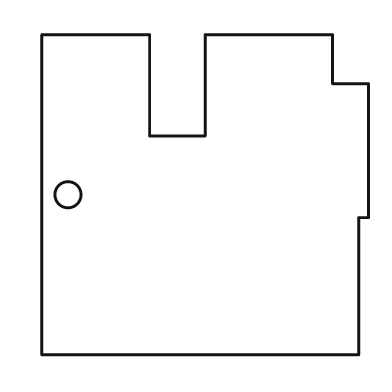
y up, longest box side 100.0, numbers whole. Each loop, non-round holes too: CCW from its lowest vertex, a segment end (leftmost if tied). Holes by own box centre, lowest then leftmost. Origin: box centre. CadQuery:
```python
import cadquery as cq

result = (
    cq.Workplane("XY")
    .moveTo(-50.0, -49.0)
    .lineTo(47.0, -49.0)
    .lineTo(47.0, -7.0)
    .lineTo(50.0, -7.0)
    .lineTo(50.0, 34.0)
    .lineTo(39.0, 34.0)
    .lineTo(39.0, 49.0)
    .lineTo(0.0, 49.0)
    .lineTo(0.0, 18.0)
    .lineTo(-17.0, 18.0)
    .lineTo(-17.0, 49.0)
    .lineTo(-50.0, 49.0)
    .close()
    .moveTo(-42.0, 0.0)
    .circle(4.0)
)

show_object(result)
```